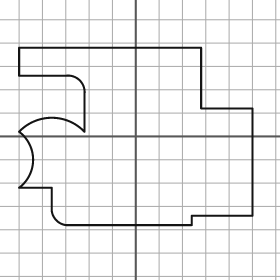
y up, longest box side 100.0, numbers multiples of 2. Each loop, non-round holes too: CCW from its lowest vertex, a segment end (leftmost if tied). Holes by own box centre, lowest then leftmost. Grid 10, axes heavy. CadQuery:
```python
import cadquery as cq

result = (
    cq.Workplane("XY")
    .moveTo(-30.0, -38.0)
    .lineTo(24.0, -38.0)
    .lineTo(24.0, -34.0)
    .lineTo(50.0, -34.0)
    .lineTo(50.0, 12.0)
    .lineTo(28.0, 12.0)
    .lineTo(28.0, 38.0)
    .lineTo(-50.0, 38.0)
    .lineTo(-50.0, 26.0)
    .lineTo(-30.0, 26.0)
    .threePointArc((-24.0, 24.0), (-22.0, 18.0))
    .lineTo(-22.0, 2.0)
    .threePointArc((-36.0, 8.0), (-50.0, 2.0))
    .threePointArc((-44.0, -10.0), (-50.0, -22.0))
    .lineTo(-36.0, -22.0)
    .lineTo(-36.0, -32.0)
    .threePointArc((-34.0, -36.0), (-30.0, -38.0))
    .close()
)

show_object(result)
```